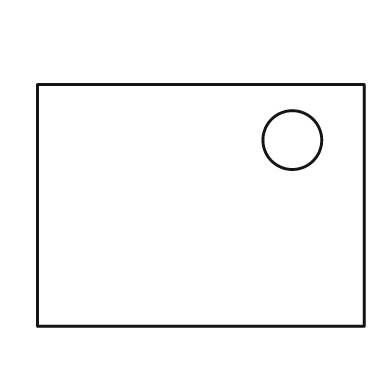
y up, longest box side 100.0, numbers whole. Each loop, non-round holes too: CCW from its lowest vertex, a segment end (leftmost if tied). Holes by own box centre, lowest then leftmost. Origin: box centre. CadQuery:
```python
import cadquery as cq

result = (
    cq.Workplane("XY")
    .moveTo(-50.0, -37.0)
    .lineTo(50.0, -37.0)
    .lineTo(50.0, 37.0)
    .lineTo(-50.0, 37.0)
    .close()
    .moveTo(28.0, 20.0)
    .circle(9.0)
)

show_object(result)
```